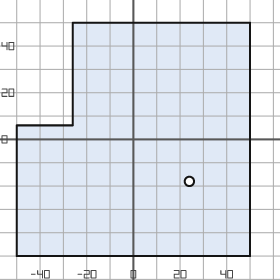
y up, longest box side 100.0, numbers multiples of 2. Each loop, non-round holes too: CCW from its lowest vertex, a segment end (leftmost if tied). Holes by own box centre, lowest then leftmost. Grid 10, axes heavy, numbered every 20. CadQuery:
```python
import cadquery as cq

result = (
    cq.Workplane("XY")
    .moveTo(-50.0, -50.0)
    .lineTo(50.0, -50.0)
    .lineTo(50.0, 50.0)
    .lineTo(-26.0, 50.0)
    .lineTo(-26.0, 6.0)
    .lineTo(-50.0, 6.0)
    .close()
    .moveTo(24.0, -18.0)
    .circle(2.0)
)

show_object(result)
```